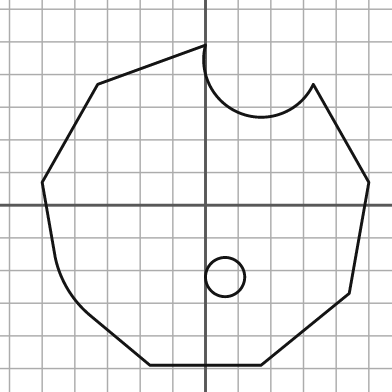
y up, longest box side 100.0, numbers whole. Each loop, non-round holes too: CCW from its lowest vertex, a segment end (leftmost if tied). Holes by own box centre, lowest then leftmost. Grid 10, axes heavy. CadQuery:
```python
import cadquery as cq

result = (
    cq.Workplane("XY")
    .moveTo(-17.0, -49.0)
    .lineTo(17.0, -49.0)
    .lineTo(44.0, -27.0)
    .lineTo(50.0, 7.0)
    .lineTo(33.0, 37.0)
    .threePointArc((11.0, 28.0), (0.0, 49.0))
    .lineTo(-33.0, 37.0)
    .lineTo(-50.0, 7.0)
    .lineTo(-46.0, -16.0)
    .threePointArc((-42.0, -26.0), (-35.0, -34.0))
    .close()
    .moveTo(6.0, -22.0)
    .circle(6.0)
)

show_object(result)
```